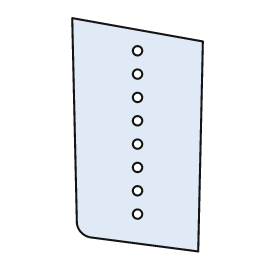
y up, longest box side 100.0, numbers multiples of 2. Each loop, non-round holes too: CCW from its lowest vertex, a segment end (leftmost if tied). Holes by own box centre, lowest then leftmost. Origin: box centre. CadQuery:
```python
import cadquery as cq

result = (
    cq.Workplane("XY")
    .moveTo(26.0, -50.0)
    .lineTo(28.0, 40.0)
    .lineTo(-28.0, 50.0)
    .lineTo(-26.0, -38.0)
    .threePointArc((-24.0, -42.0), (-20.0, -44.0))
    .close()
    .moveTo(0.0, -34.0)
    .circle(2.0)
    .moveTo(0.0, -24.0)
    .circle(2.0)
    .moveTo(0.0, -14.0)
    .circle(2.0)
    .moveTo(0.0, -4.0)
    .circle(2.0)
    .moveTo(0.0, 6.0)
    .circle(2.0)
    .moveTo(0.0, 16.0)
    .circle(2.0)
    .moveTo(0.0, 26.0)
    .circle(2.0)
    .moveTo(0.0, 36.0)
    .circle(2.0)
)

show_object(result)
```